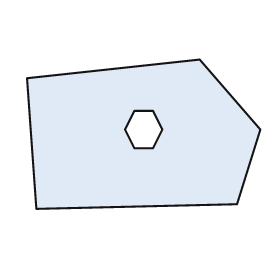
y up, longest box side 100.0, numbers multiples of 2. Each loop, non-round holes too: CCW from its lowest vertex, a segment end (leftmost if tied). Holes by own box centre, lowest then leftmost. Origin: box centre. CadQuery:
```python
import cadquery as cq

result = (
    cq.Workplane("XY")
    .moveTo(-46.0, -32.0)
    .lineTo(40.0, -30.0)
    .lineTo(50.0, 2.0)
    .lineTo(24.0, 32.0)
    .lineTo(-50.0, 24.0)
    .close()
    .moveTo(-4.0, -6.0)
    .lineTo(4.0, -6.0)
    .lineTo(8.0, 2.0)
    .lineTo(4.0, 10.0)
    .lineTo(-4.0, 10.0)
    .lineTo(-8.0, 2.0)
    .close()
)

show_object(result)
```